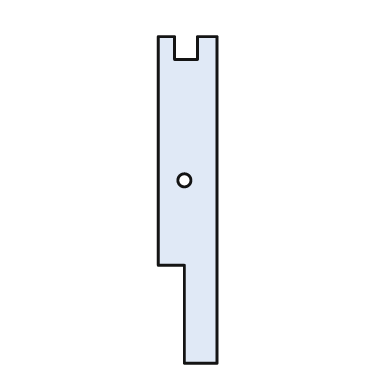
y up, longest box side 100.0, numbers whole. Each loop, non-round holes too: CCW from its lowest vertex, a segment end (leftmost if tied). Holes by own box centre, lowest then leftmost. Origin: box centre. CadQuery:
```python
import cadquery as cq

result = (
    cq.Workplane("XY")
    .moveTo(-1.0, -50.0)
    .lineTo(9.0, -50.0)
    .lineTo(9.0, 50.0)
    .lineTo(3.0, 50.0)
    .lineTo(3.0, 43.0)
    .lineTo(-4.0, 43.0)
    .lineTo(-4.0, 50.0)
    .lineTo(-9.0, 50.0)
    .lineTo(-9.0, -20.0)
    .lineTo(-1.0, -20.0)
    .close()
    .moveTo(-1.0, 6.0)
    .circle(2.0)
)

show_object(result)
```